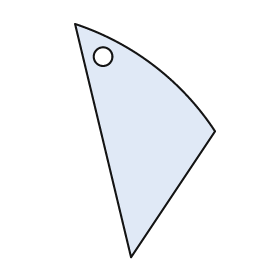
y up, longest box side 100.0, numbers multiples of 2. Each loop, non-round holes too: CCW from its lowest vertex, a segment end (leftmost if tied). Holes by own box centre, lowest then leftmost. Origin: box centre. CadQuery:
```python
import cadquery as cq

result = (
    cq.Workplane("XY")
    .moveTo(-6.0, -50.0)
    .lineTo(30.0, 4.0)
    .threePointArc((4.0, 32.0), (-30.0, 50.0))
    .close()
    .moveTo(-18.0, 36.0)
    .circle(4.0)
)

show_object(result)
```